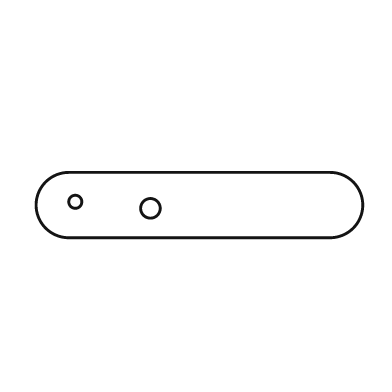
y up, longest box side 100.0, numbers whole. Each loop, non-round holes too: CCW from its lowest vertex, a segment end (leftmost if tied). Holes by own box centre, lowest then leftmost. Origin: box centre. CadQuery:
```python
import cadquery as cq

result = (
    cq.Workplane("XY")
    .moveTo(-40.0, -10.0)
    .lineTo(40.0, -10.0)
    .threePointArc((50.0, 0.0), (40.0, 10.0))
    .lineTo(-40.0, 10.0)
    .threePointArc((-50.0, 0.0), (-40.0, -10.0))
    .close()
    .moveTo(-15.0, -1.0)
    .circle(3.0)
    .moveTo(-38.0, 1.0)
    .circle(2.0)
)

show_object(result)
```